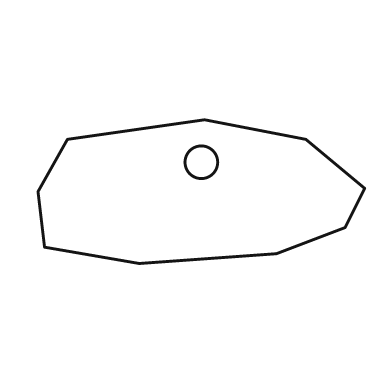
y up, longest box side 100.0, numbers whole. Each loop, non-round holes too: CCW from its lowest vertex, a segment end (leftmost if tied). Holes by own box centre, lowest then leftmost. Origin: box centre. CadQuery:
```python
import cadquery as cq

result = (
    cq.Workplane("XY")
    .moveTo(-19.0, -22.0)
    .lineTo(23.0, -19.0)
    .lineTo(44.0, -11.0)
    .lineTo(50.0, 1.0)
    .lineTo(32.0, 16.0)
    .lineTo(1.0, 22.0)
    .lineTo(-41.0, 16.0)
    .lineTo(-50.0, 0.0)
    .lineTo(-48.0, -17.0)
    .close()
    .moveTo(0.0, 9.0)
    .circle(5.0)
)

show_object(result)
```